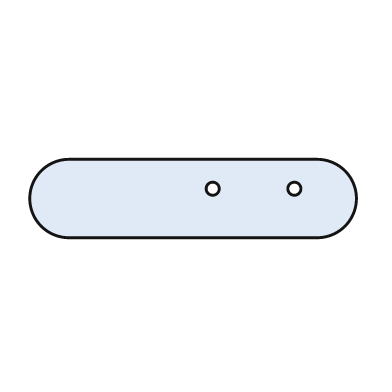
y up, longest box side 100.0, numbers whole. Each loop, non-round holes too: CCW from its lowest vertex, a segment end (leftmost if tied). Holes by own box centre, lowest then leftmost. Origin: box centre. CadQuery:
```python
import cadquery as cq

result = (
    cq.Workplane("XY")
    .moveTo(-38.0, -12.0)
    .lineTo(38.0, -12.0)
    .threePointArc((50.0, 0.0), (38.0, 12.0))
    .lineTo(-38.0, 12.0)
    .threePointArc((-50.0, 0.0), (-38.0, -12.0))
    .close()
    .moveTo(6.0, 3.0)
    .circle(2.0)
    .moveTo(31.0, 3.0)
    .circle(2.0)
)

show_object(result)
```